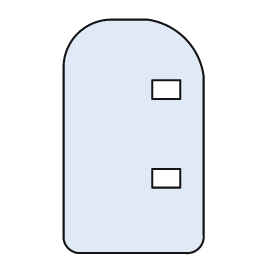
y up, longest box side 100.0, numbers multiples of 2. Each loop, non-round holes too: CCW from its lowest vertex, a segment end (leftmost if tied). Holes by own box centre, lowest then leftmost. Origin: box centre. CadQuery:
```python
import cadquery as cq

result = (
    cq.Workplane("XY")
    .moveTo(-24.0, -50.0)
    .lineTo(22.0, -50.0)
    .threePointArc((28.0, -48.0), (30.0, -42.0))
    .lineTo(30.0, 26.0)
    .threePointArc((22.0, 42.0), (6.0, 50.0))
    .lineTo(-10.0, 50.0)
    .threePointArc((-24.0, 44.0), (-30.0, 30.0))
    .lineTo(-30.0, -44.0)
    .threePointArc((-28.0, -48.0), (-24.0, -50.0))
    .close()
    .moveTo(8.0, -22.0)
    .lineTo(20.0, -22.0)
    .lineTo(20.0, -14.0)
    .lineTo(8.0, -14.0)
    .close()
    .moveTo(8.0, 16.0)
    .lineTo(20.0, 16.0)
    .lineTo(20.0, 24.0)
    .lineTo(8.0, 24.0)
    .close()
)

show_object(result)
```